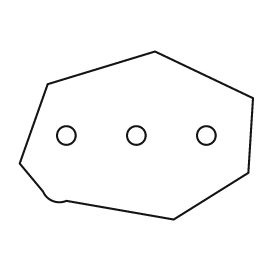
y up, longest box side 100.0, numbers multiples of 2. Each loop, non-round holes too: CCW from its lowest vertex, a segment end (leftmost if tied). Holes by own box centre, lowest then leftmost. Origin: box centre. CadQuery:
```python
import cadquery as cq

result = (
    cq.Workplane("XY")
    .moveTo(16.0, -36.0)
    .lineTo(48.0, -16.0)
    .lineTo(50.0, 16.0)
    .lineTo(8.0, 36.0)
    .lineTo(-38.0, 22.0)
    .lineTo(-50.0, -12.0)
    .lineTo(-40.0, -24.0)
    .threePointArc((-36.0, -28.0), (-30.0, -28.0))
    .close()
    .moveTo(-30.0, 0.0)
    .circle(4.0)
    .moveTo(0.0, 0.0)
    .circle(4.0)
    .moveTo(30.0, 0.0)
    .circle(4.0)
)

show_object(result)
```